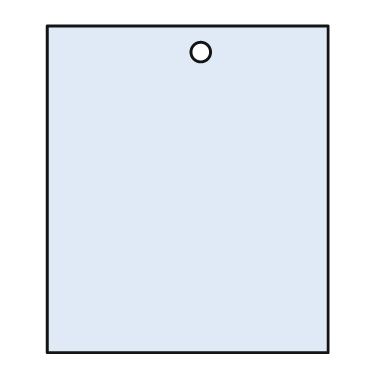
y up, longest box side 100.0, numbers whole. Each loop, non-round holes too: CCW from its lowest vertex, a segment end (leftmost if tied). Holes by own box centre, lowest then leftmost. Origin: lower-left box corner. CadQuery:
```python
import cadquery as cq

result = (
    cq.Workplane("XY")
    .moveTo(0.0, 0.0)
    .lineTo(86.0, 0.0)
    .lineTo(86.0, 100.0)
    .lineTo(0.0, 100.0)
    .close()
    .moveTo(47.0, 92.0)
    .circle(3.0)
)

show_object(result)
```